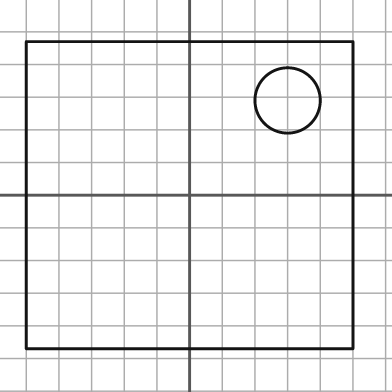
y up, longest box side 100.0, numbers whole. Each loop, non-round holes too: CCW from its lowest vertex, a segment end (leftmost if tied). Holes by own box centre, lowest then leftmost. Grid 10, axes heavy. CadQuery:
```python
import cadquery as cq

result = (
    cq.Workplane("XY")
    .moveTo(-50.0, -47.0)
    .lineTo(50.0, -47.0)
    .lineTo(50.0, 47.0)
    .lineTo(-50.0, 47.0)
    .close()
    .moveTo(30.0, 29.0)
    .circle(10.0)
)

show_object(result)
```